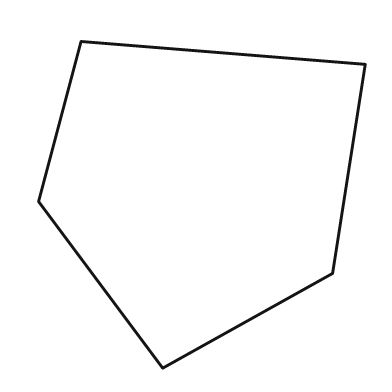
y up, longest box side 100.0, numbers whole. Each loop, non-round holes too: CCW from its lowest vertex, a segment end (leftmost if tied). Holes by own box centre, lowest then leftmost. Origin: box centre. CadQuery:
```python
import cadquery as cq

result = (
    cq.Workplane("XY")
    .moveTo(-12.0, -50.0)
    .lineTo(40.0, -21.0)
    .lineTo(50.0, 43.0)
    .lineTo(-37.0, 50.0)
    .lineTo(-50.0, 1.0)
    .close()
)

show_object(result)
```